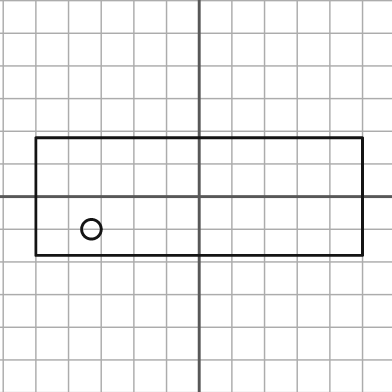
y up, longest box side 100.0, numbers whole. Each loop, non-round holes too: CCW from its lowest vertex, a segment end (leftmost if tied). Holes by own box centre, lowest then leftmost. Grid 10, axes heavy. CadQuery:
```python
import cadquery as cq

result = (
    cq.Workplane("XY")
    .moveTo(-50.0, -18.0)
    .lineTo(50.0, -18.0)
    .lineTo(50.0, 18.0)
    .lineTo(-50.0, 18.0)
    .close()
    .moveTo(-33.0, -10.0)
    .circle(3.0)
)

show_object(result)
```